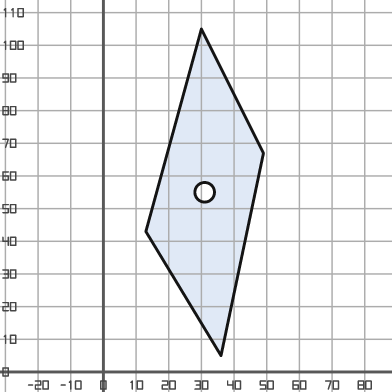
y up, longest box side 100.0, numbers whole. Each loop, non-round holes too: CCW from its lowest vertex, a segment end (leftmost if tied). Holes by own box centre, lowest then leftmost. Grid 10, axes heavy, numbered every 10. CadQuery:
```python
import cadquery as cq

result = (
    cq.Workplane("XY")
    .moveTo(36.0, 5.0)
    .lineTo(49.0, 67.0)
    .lineTo(30.0, 105.0)
    .lineTo(13.0, 43.0)
    .close()
    .moveTo(31.0, 55.0)
    .circle(3.0)
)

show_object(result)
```